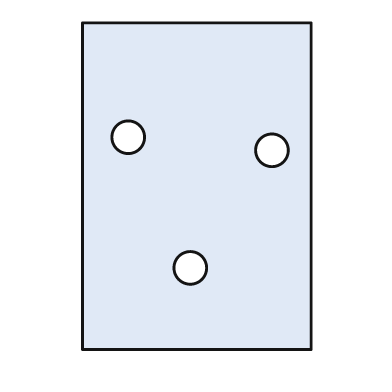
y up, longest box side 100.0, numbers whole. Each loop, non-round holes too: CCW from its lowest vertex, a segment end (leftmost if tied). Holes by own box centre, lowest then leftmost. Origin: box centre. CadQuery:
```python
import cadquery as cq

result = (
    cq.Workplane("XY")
    .moveTo(-35.0, -50.0)
    .lineTo(35.0, -50.0)
    .lineTo(35.0, 50.0)
    .lineTo(-35.0, 50.0)
    .close()
    .moveTo(-2.0, -25.0)
    .circle(5.0)
    .moveTo(23.0, 11.0)
    .circle(5.0)
    .moveTo(-21.0, 15.0)
    .circle(5.0)
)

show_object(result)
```